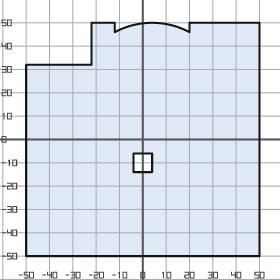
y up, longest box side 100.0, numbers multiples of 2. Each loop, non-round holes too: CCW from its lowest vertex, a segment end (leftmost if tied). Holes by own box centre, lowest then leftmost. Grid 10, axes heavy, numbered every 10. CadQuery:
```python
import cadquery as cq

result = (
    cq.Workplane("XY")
    .moveTo(-50.0, -50.0)
    .lineTo(50.0, -50.0)
    .lineTo(50.0, 50.0)
    .lineTo(20.0, 50.0)
    .lineTo(20.0, 46.0)
    .threePointArc((4.0, 50.0), (-12.0, 46.0))
    .lineTo(-12.0, 50.0)
    .lineTo(-22.0, 50.0)
    .lineTo(-22.0, 32.0)
    .lineTo(-50.0, 32.0)
    .close()
    .moveTo(-4.0, -14.0)
    .lineTo(4.0, -14.0)
    .lineTo(4.0, -6.0)
    .lineTo(-4.0, -6.0)
    .close()
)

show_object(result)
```